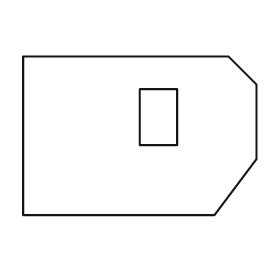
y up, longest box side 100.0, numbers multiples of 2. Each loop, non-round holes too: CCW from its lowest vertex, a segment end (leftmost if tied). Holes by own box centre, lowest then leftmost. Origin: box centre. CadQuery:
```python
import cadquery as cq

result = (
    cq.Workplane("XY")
    .moveTo(-50.0, -34.0)
    .lineTo(32.0, -34.0)
    .lineTo(50.0, -10.0)
    .lineTo(50.0, 22.0)
    .lineTo(38.0, 34.0)
    .lineTo(-50.0, 34.0)
    .close()
    .moveTo(0.0, -4.0)
    .lineTo(16.0, -4.0)
    .lineTo(16.0, 20.0)
    .lineTo(0.0, 20.0)
    .close()
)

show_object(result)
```